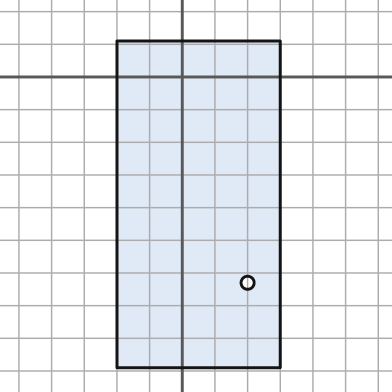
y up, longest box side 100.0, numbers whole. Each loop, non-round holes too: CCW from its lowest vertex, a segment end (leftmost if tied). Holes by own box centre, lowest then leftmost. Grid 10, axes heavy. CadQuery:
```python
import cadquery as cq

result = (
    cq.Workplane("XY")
    .moveTo(-20.0, -89.0)
    .lineTo(30.0, -89.0)
    .lineTo(30.0, 11.0)
    .lineTo(-20.0, 11.0)
    .close()
    .moveTo(20.0, -63.0)
    .circle(2.0)
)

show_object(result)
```